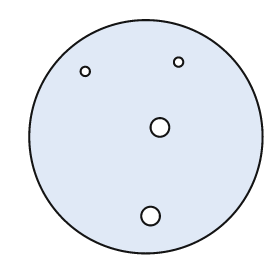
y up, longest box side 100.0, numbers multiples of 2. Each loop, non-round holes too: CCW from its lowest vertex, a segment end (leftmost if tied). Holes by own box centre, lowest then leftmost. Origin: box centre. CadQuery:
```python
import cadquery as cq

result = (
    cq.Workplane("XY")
    .moveTo(0.0, 0.0)
    .circle(50.0)
    .moveTo(2.0, -34.0)
    .circle(4.0)
    .moveTo(6.0, 4.0)
    .circle(4.0)
    .moveTo(-26.0, 28.0)
    .circle(2.0)
    .moveTo(14.0, 32.0)
    .circle(2.0)
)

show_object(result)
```